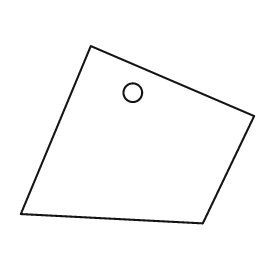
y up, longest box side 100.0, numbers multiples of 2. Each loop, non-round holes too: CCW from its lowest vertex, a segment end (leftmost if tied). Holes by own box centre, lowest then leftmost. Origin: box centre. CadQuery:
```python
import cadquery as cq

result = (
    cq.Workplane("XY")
    .moveTo(28.0, -38.0)
    .lineTo(50.0, 8.0)
    .lineTo(-20.0, 38.0)
    .lineTo(-50.0, -34.0)
    .close()
    .moveTo(-2.0, 18.0)
    .circle(4.0)
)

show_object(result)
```